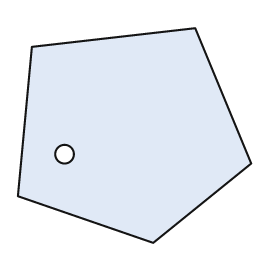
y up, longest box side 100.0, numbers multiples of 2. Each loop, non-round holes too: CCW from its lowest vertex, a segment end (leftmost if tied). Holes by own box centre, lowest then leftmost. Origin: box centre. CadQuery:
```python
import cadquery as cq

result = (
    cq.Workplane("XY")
    .moveTo(8.0, -46.0)
    .lineTo(50.0, -12.0)
    .lineTo(26.0, 46.0)
    .lineTo(-44.0, 38.0)
    .lineTo(-50.0, -26.0)
    .close()
    .moveTo(-30.0, -8.0)
    .circle(4.0)
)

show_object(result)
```